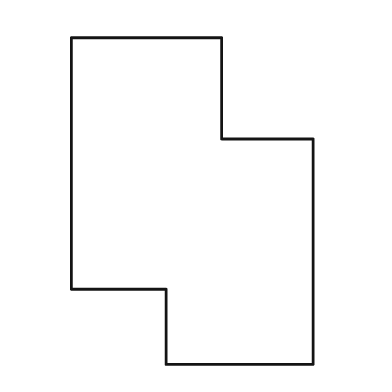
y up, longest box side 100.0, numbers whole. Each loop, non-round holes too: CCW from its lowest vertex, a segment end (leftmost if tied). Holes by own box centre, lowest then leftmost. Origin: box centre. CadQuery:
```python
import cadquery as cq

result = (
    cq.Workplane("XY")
    .moveTo(-8.0, -50.0)
    .lineTo(37.0, -50.0)
    .lineTo(37.0, 19.0)
    .lineTo(9.0, 19.0)
    .lineTo(9.0, 50.0)
    .lineTo(-37.0, 50.0)
    .lineTo(-37.0, -27.0)
    .lineTo(-8.0, -27.0)
    .close()
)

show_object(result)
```